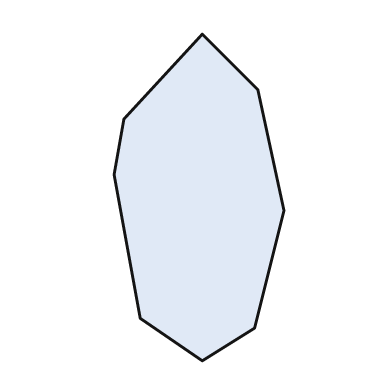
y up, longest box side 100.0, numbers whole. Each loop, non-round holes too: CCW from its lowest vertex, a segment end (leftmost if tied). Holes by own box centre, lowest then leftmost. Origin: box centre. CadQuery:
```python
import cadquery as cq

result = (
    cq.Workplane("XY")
    .moveTo(1.0, -50.0)
    .lineTo(17.0, -40.0)
    .lineTo(26.0, -4.0)
    .lineTo(18.0, 33.0)
    .lineTo(1.0, 50.0)
    .lineTo(-23.0, 24.0)
    .lineTo(-26.0, 7.0)
    .lineTo(-18.0, -37.0)
    .close()
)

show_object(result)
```